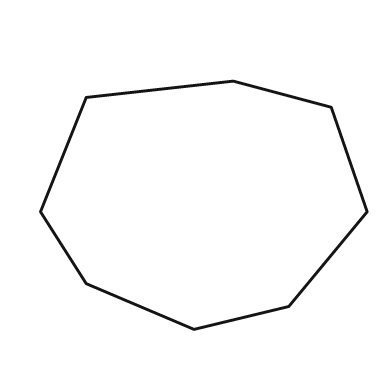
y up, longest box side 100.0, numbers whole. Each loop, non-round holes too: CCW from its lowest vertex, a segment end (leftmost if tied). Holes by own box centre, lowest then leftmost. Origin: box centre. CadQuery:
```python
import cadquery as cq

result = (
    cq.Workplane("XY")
    .moveTo(-3.0, -38.0)
    .lineTo(26.0, -31.0)
    .lineTo(50.0, -2.0)
    .lineTo(39.0, 30.0)
    .lineTo(9.0, 38.0)
    .lineTo(-36.0, 33.0)
    .lineTo(-50.0, -2.0)
    .lineTo(-36.0, -24.0)
    .close()
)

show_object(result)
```